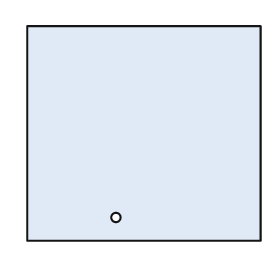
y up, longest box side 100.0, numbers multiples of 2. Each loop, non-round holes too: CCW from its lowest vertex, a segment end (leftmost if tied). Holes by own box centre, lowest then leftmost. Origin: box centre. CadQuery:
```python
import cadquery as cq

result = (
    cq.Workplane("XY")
    .moveTo(-50.0, -46.0)
    .lineTo(50.0, -46.0)
    .lineTo(50.0, 46.0)
    .lineTo(-50.0, 46.0)
    .close()
    .moveTo(-12.0, -36.0)
    .circle(2.0)
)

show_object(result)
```